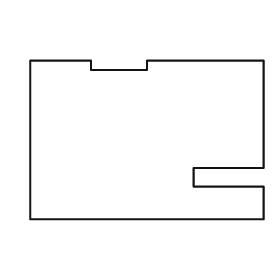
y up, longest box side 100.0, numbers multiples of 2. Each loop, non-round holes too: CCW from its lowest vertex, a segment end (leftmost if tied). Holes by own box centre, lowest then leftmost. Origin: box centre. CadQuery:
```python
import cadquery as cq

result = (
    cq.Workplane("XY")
    .moveTo(-50.0, -34.0)
    .lineTo(50.0, -34.0)
    .lineTo(50.0, -20.0)
    .lineTo(20.0, -20.0)
    .lineTo(20.0, -12.0)
    .lineTo(50.0, -12.0)
    .lineTo(50.0, 34.0)
    .lineTo(0.0, 34.0)
    .lineTo(0.0, 30.0)
    .lineTo(-24.0, 30.0)
    .lineTo(-24.0, 34.0)
    .lineTo(-50.0, 34.0)
    .close()
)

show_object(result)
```